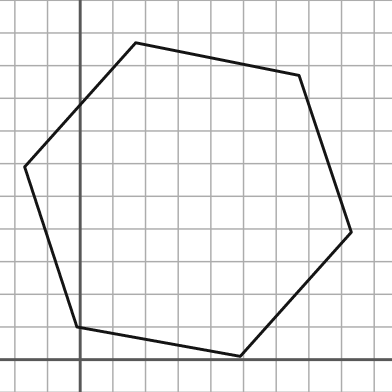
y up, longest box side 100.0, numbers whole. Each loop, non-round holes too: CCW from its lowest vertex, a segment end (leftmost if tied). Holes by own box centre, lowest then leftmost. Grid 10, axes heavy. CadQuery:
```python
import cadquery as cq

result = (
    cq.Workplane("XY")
    .moveTo(49.0, 1.0)
    .lineTo(83.0, 39.0)
    .lineTo(67.0, 87.0)
    .lineTo(17.0, 97.0)
    .lineTo(-17.0, 59.0)
    .lineTo(-1.0, 10.0)
    .close()
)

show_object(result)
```